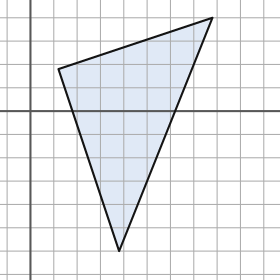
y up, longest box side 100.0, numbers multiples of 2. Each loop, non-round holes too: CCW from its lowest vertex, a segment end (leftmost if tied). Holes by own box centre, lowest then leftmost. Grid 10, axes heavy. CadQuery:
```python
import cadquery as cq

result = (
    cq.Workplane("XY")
    .moveTo(38.0, -60.0)
    .lineTo(78.0, 40.0)
    .lineTo(12.0, 18.0)
    .close()
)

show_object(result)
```